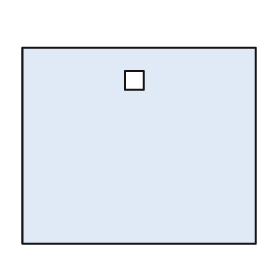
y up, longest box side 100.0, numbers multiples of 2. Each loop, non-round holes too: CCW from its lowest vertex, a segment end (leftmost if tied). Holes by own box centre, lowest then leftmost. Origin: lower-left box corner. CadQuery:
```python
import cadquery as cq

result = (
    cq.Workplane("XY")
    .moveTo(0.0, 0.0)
    .lineTo(100.0, 0.0)
    .lineTo(100.0, 84.0)
    .lineTo(0.0, 84.0)
    .close()
    .moveTo(44.0, 66.0)
    .lineTo(52.0, 66.0)
    .lineTo(52.0, 74.0)
    .lineTo(44.0, 74.0)
    .close()
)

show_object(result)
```